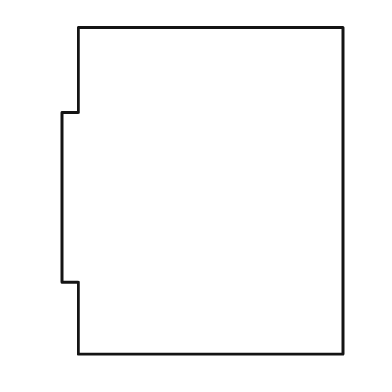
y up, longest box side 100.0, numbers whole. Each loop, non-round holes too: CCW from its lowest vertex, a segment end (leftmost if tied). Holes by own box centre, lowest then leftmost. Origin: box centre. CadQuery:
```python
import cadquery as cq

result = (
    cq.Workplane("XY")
    .moveTo(-38.0, -50.0)
    .lineTo(43.0, -50.0)
    .lineTo(43.0, 50.0)
    .lineTo(-38.0, 50.0)
    .lineTo(-38.0, 24.0)
    .lineTo(-43.0, 24.0)
    .lineTo(-43.0, -28.0)
    .lineTo(-38.0, -28.0)
    .close()
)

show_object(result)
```